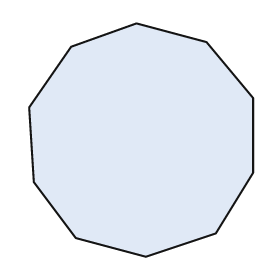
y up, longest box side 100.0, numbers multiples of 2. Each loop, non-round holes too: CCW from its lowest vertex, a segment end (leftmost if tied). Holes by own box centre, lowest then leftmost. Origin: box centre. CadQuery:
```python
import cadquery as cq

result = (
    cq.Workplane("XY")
    .moveTo(2.0, -50.0)
    .lineTo(32.0, -40.0)
    .lineTo(48.0, -14.0)
    .lineTo(48.0, 18.0)
    .lineTo(28.0, 42.0)
    .lineTo(-2.0, 50.0)
    .lineTo(-30.0, 40.0)
    .lineTo(-48.0, 14.0)
    .lineTo(-46.0, -18.0)
    .lineTo(-28.0, -42.0)
    .close()
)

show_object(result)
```